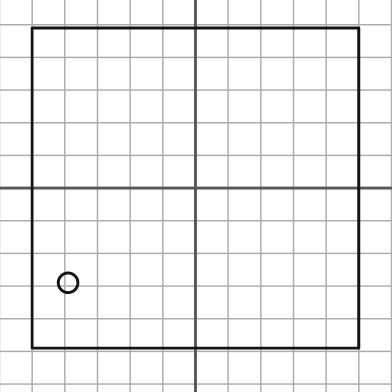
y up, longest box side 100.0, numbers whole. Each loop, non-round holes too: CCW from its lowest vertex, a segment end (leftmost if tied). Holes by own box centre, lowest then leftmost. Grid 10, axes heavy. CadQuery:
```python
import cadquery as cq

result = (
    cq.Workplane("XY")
    .moveTo(-50.0, -49.0)
    .lineTo(50.0, -49.0)
    .lineTo(50.0, 49.0)
    .lineTo(-50.0, 49.0)
    .close()
    .moveTo(-39.0, -29.0)
    .circle(3.0)
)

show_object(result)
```